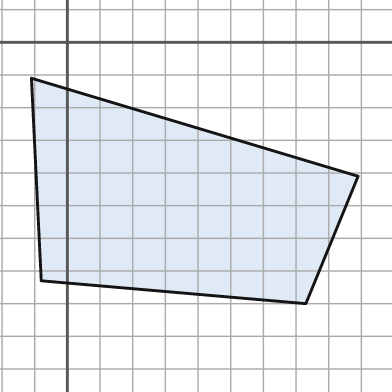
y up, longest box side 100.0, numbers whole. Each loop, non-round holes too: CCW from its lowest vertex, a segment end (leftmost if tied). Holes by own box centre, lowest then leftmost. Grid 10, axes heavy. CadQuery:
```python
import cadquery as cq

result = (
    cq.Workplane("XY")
    .moveTo(73.0, -80.0)
    .lineTo(89.0, -41.0)
    .lineTo(-11.0, -11.0)
    .lineTo(-8.0, -73.0)
    .close()
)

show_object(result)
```